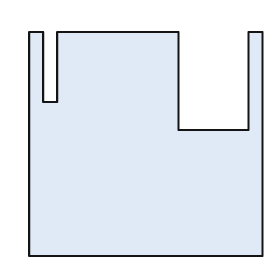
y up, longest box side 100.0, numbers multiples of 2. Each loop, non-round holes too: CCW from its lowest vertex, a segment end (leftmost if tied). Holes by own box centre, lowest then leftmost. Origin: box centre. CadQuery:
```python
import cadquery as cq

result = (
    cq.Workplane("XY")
    .moveTo(-50.0, -48.0)
    .lineTo(50.0, -48.0)
    .lineTo(50.0, 48.0)
    .lineTo(44.0, 48.0)
    .lineTo(44.0, 6.0)
    .lineTo(14.0, 6.0)
    .lineTo(14.0, 48.0)
    .lineTo(-38.0, 48.0)
    .lineTo(-38.0, 18.0)
    .lineTo(-44.0, 18.0)
    .lineTo(-44.0, 48.0)
    .lineTo(-50.0, 48.0)
    .close()
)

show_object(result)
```